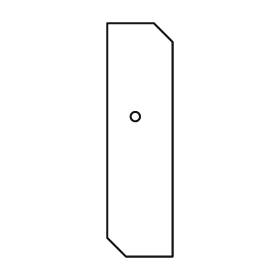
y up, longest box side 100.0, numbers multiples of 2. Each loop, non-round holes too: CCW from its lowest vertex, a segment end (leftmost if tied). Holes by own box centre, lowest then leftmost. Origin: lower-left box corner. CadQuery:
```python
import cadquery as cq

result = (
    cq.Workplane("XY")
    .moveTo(8.0, 0.0)
    .lineTo(28.0, 0.0)
    .lineTo(28.0, 92.0)
    .lineTo(20.0, 100.0)
    .lineTo(0.0, 100.0)
    .lineTo(0.0, 8.0)
    .close()
    .moveTo(12.0, 60.0)
    .circle(2.0)
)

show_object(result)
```